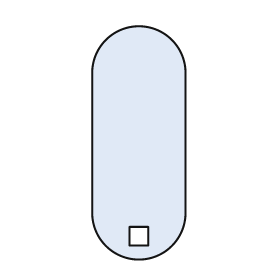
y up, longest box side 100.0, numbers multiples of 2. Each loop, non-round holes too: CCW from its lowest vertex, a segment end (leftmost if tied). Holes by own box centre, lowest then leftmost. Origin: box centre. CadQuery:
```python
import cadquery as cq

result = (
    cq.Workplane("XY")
    .moveTo(-20.0, -30.0)
    .threePointArc((0.0, -50.0), (20.0, -30.0))
    .lineTo(20.0, 30.0)
    .threePointArc((0.0, 50.0), (-20.0, 30.0))
    .close()
    .moveTo(-4.0, -44.0)
    .lineTo(4.0, -44.0)
    .lineTo(4.0, -36.0)
    .lineTo(-4.0, -36.0)
    .close()
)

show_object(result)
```